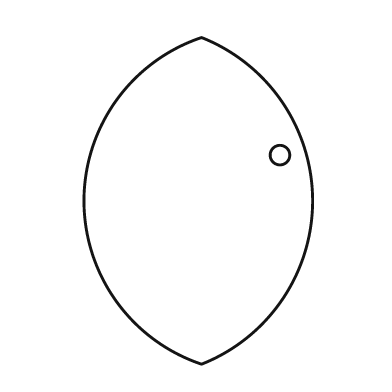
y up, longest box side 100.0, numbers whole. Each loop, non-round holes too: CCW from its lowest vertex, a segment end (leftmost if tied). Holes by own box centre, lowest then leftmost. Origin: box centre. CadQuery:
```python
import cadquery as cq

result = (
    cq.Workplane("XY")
    .moveTo(1.0, -50.0)
    .threePointArc((35.0, 0.0), (1.0, 50.0))
    .threePointArc((-35.0, 0.0), (1.0, -50.0))
    .close()
    .moveTo(25.0, 14.0)
    .circle(3.0)
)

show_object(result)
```